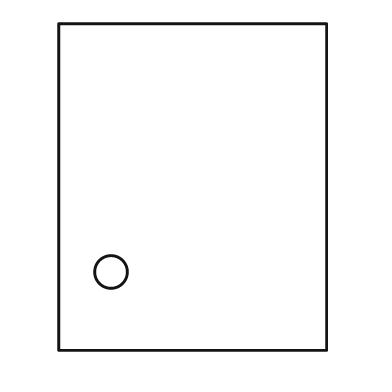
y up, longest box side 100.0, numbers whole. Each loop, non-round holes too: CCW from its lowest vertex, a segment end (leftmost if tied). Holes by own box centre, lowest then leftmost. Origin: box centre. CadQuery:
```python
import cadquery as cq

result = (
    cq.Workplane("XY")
    .moveTo(-41.0, -50.0)
    .lineTo(41.0, -50.0)
    .lineTo(41.0, 50.0)
    .lineTo(-41.0, 50.0)
    .close()
    .moveTo(-25.0, -26.0)
    .circle(5.0)
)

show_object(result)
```